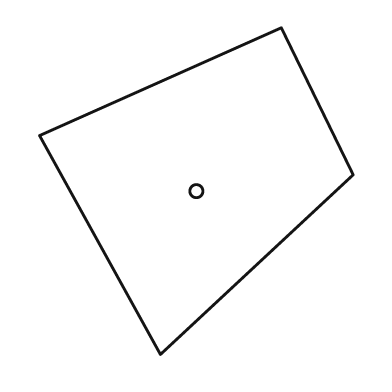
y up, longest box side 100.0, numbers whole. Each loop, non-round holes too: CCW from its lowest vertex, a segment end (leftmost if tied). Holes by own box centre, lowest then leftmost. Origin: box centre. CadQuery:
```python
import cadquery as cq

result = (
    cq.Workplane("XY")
    .moveTo(-11.0, -50.0)
    .lineTo(48.0, 5.0)
    .lineTo(26.0, 50.0)
    .lineTo(-48.0, 17.0)
    .close()
    .moveTo(0.0, 0.0)
    .circle(2.0)
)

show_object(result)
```